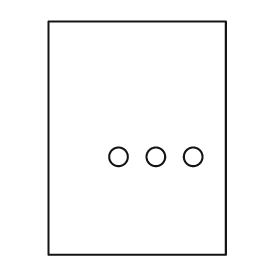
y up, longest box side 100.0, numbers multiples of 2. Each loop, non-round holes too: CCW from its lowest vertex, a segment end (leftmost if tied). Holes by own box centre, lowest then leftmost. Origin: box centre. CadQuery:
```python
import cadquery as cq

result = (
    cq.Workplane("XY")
    .moveTo(-38.0, -50.0)
    .lineTo(38.0, -50.0)
    .lineTo(38.0, 50.0)
    .lineTo(-38.0, 50.0)
    .close()
    .moveTo(-8.0, -8.0)
    .circle(4.0)
    .moveTo(8.0, -8.0)
    .circle(4.0)
    .moveTo(24.0, -8.0)
    .circle(4.0)
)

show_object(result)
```